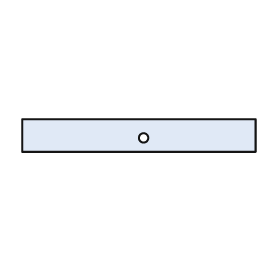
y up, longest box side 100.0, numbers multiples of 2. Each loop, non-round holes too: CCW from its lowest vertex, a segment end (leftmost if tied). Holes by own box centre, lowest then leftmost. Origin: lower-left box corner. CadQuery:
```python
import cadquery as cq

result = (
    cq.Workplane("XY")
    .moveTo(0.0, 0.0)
    .lineTo(100.0, 0.0)
    .lineTo(100.0, 14.0)
    .lineTo(0.0, 14.0)
    .close()
    .moveTo(52.0, 6.0)
    .circle(2.0)
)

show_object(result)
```